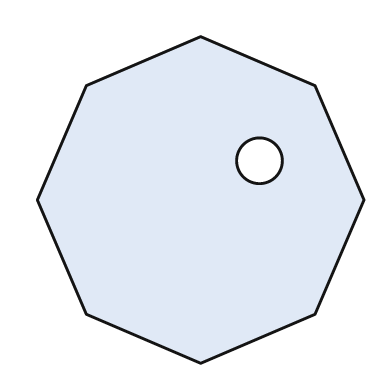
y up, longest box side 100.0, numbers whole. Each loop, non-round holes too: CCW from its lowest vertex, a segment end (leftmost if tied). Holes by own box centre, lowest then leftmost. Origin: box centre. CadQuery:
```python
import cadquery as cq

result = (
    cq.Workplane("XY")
    .moveTo(0.0, -50.0)
    .lineTo(35.0, -35.0)
    .lineTo(50.0, 0.0)
    .lineTo(35.0, 35.0)
    .lineTo(0.0, 50.0)
    .lineTo(-35.0, 35.0)
    .lineTo(-50.0, 0.0)
    .lineTo(-35.0, -35.0)
    .close()
    .moveTo(18.0, 12.0)
    .circle(7.0)
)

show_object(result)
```